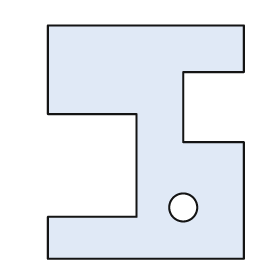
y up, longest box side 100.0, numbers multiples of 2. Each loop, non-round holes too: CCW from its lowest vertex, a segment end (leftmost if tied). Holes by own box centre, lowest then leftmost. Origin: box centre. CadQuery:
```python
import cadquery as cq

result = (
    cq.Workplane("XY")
    .moveTo(-42.0, -50.0)
    .lineTo(42.0, -50.0)
    .lineTo(42.0, 0.0)
    .lineTo(16.0, 0.0)
    .lineTo(16.0, 30.0)
    .lineTo(42.0, 30.0)
    .lineTo(42.0, 50.0)
    .lineTo(-42.0, 50.0)
    .lineTo(-42.0, 12.0)
    .lineTo(-4.0, 12.0)
    .lineTo(-4.0, -32.0)
    .lineTo(-42.0, -32.0)
    .close()
    .moveTo(16.0, -28.0)
    .circle(6.0)
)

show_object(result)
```